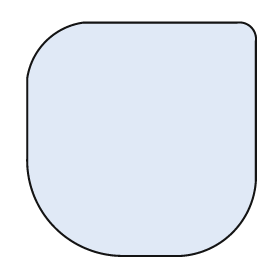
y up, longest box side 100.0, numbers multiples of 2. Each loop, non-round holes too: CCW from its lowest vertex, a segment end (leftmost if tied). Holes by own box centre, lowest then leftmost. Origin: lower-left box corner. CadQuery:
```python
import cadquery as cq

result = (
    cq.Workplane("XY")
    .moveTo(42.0, 0.0)
    .lineTo(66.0, 0.0)
    .threePointArc((88.0, 10.0), (98.0, 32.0))
    .lineTo(98.0, 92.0)
    .threePointArc((96.0, 98.0), (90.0, 100.0))
    .lineTo(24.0, 100.0)
    .threePointArc((8.0, 92.0), (0.0, 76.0))
    .lineTo(0.0, 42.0)
    .threePointArc((12.0, 12.0), (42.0, 0.0))
    .close()
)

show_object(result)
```